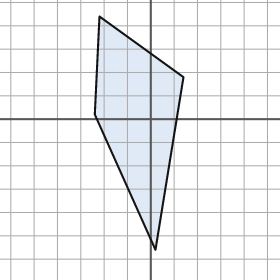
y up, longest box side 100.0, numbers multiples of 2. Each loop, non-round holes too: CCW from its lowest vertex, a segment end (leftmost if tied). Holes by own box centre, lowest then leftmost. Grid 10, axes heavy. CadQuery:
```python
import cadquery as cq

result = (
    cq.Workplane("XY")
    .moveTo(2.0, -56.0)
    .lineTo(14.0, 18.0)
    .lineTo(-22.0, 44.0)
    .lineTo(-24.0, 2.0)
    .close()
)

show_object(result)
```